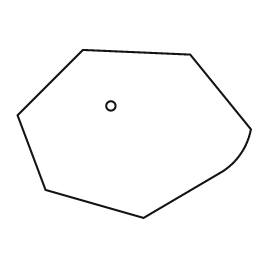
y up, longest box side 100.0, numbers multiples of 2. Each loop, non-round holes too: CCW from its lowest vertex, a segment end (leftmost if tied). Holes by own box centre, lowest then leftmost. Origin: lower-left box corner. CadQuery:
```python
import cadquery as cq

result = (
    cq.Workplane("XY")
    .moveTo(54.0, 0.0)
    .lineTo(88.0, 20.0)
    .threePointArc((96.0, 28.0), (100.0, 38.0))
    .lineTo(74.0, 70.0)
    .lineTo(28.0, 72.0)
    .lineTo(0.0, 44.0)
    .lineTo(12.0, 12.0)
    .close()
    .moveTo(40.0, 48.0)
    .circle(2.0)
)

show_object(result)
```